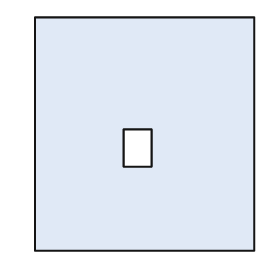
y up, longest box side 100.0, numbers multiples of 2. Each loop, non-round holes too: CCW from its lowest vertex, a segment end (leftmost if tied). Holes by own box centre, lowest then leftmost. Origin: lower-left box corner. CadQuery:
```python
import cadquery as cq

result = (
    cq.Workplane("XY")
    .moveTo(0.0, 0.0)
    .lineTo(94.0, 0.0)
    .lineTo(94.0, 100.0)
    .lineTo(0.0, 100.0)
    .close()
    .moveTo(38.0, 36.0)
    .lineTo(50.0, 36.0)
    .lineTo(50.0, 52.0)
    .lineTo(38.0, 52.0)
    .close()
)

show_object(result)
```